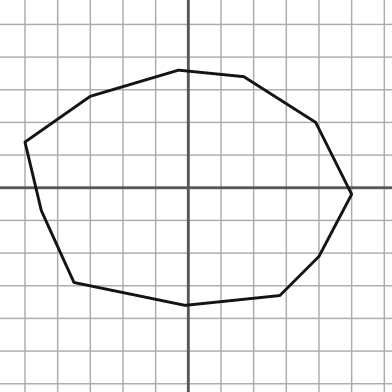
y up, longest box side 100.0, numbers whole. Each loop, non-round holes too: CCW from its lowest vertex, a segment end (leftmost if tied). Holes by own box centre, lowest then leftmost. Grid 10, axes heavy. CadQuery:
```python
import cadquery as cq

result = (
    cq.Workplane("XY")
    .moveTo(-1.0, -36.0)
    .lineTo(28.0, -33.0)
    .lineTo(40.0, -21.0)
    .lineTo(50.0, -2.0)
    .lineTo(39.0, 20.0)
    .lineTo(17.0, 34.0)
    .lineTo(-3.0, 36.0)
    .lineTo(-30.0, 28.0)
    .lineTo(-50.0, 14.0)
    .lineTo(-45.0, -7.0)
    .lineTo(-35.0, -29.0)
    .close()
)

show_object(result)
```